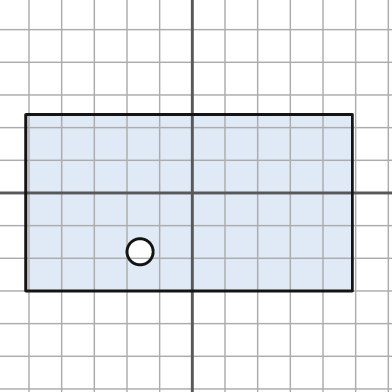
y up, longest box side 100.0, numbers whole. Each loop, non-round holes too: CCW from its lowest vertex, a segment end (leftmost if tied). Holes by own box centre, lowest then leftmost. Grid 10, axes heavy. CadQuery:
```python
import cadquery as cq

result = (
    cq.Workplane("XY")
    .moveTo(-51.0, -30.0)
    .lineTo(49.0, -30.0)
    .lineTo(49.0, 24.0)
    .lineTo(-51.0, 24.0)
    .close()
    .moveTo(-16.0, -18.0)
    .circle(4.0)
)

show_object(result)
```